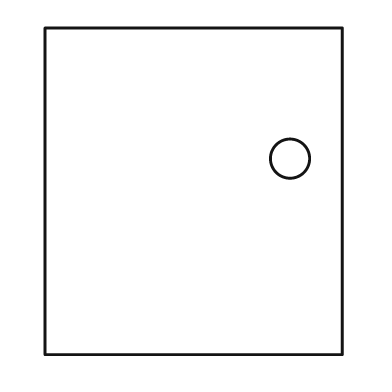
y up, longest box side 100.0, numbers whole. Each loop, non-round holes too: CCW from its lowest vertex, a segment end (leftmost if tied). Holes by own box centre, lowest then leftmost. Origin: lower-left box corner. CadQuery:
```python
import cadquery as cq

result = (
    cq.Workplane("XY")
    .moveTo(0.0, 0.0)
    .lineTo(91.0, 0.0)
    .lineTo(91.0, 100.0)
    .lineTo(0.0, 100.0)
    .close()
    .moveTo(75.0, 60.0)
    .circle(6.0)
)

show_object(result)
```